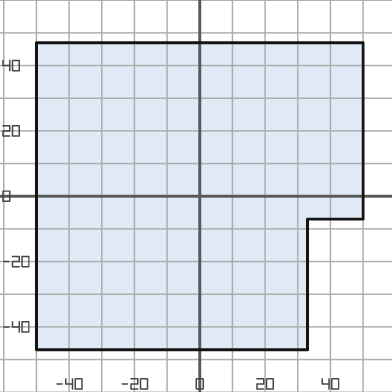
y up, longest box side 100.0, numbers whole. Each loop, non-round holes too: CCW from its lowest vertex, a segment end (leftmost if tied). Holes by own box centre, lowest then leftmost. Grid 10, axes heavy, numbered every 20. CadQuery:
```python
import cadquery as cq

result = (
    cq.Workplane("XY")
    .moveTo(-50.0, -47.0)
    .lineTo(33.0, -47.0)
    .lineTo(33.0, -7.0)
    .lineTo(50.0, -7.0)
    .lineTo(50.0, 47.0)
    .lineTo(-50.0, 47.0)
    .close()
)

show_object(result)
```